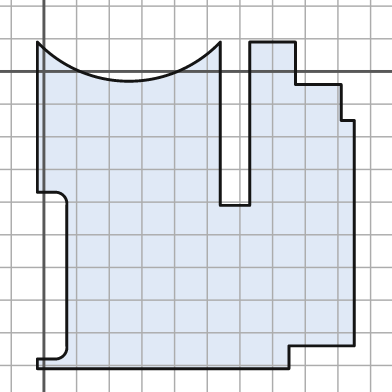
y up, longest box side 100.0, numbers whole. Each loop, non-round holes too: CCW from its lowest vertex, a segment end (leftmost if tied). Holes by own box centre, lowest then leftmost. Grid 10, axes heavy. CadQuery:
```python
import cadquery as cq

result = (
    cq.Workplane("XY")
    .moveTo(-2.0, -91.0)
    .lineTo(75.0, -91.0)
    .lineTo(75.0, -84.0)
    .lineTo(95.0, -84.0)
    .lineTo(95.0, -15.0)
    .lineTo(91.0, -15.0)
    .lineTo(91.0, -4.0)
    .lineTo(77.0, -4.0)
    .lineTo(77.0, 9.0)
    .lineTo(63.0, 9.0)
    .lineTo(63.0, -41.0)
    .lineTo(54.0, -41.0)
    .lineTo(54.0, 9.0)
    .threePointArc((26.0, -3.0), (-2.0, 9.0))
    .lineTo(-2.0, -37.0)
    .lineTo(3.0, -37.0)
    .threePointArc((6.0, -38.0), (7.0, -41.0))
    .lineTo(7.0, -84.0)
    .threePointArc((6.0, -87.0), (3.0, -88.0))
    .lineTo(-2.0, -88.0)
    .close()
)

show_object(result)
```